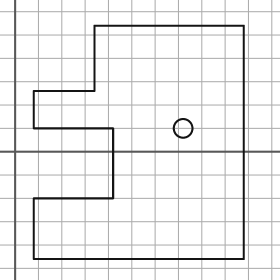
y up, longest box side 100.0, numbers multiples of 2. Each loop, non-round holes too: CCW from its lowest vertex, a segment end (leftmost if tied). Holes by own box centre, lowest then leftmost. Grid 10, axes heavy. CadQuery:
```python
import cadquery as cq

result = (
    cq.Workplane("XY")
    .moveTo(8.0, -46.0)
    .lineTo(98.0, -46.0)
    .lineTo(98.0, 54.0)
    .lineTo(34.0, 54.0)
    .lineTo(34.0, 26.0)
    .lineTo(8.0, 26.0)
    .lineTo(8.0, 10.0)
    .lineTo(42.0, 10.0)
    .lineTo(42.0, -20.0)
    .lineTo(8.0, -20.0)
    .close()
    .moveTo(72.0, 10.0)
    .circle(4.0)
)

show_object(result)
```